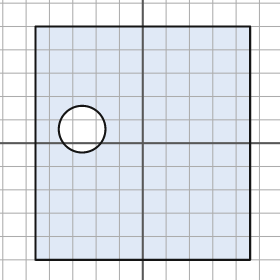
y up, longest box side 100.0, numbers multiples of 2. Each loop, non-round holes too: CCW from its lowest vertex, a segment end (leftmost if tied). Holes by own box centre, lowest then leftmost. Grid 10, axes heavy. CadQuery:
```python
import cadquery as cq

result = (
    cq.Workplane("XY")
    .moveTo(-46.0, -50.0)
    .lineTo(46.0, -50.0)
    .lineTo(46.0, 50.0)
    .lineTo(-46.0, 50.0)
    .close()
    .moveTo(-26.0, 6.0)
    .circle(10.0)
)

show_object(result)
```